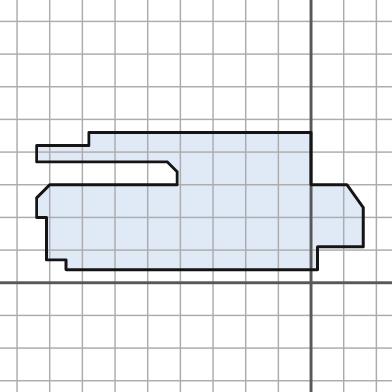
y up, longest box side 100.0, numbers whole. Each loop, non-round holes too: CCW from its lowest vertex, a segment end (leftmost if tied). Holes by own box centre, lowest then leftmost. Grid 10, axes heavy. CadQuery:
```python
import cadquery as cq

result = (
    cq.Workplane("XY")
    .moveTo(-75.0, 4.0)
    .lineTo(2.0, 4.0)
    .lineTo(2.0, 11.0)
    .lineTo(16.0, 11.0)
    .lineTo(16.0, 23.0)
    .lineTo(11.0, 30.0)
    .lineTo(0.0, 30.0)
    .lineTo(0.0, 46.0)
    .lineTo(-68.0, 46.0)
    .lineTo(-68.0, 42.0)
    .lineTo(-84.0, 42.0)
    .lineTo(-84.0, 37.0)
    .lineTo(-44.0, 37.0)
    .lineTo(-41.0, 34.0)
    .lineTo(-41.0, 30.0)
    .lineTo(-80.0, 30.0)
    .lineTo(-84.0, 26.0)
    .lineTo(-84.0, 20.0)
    .lineTo(-81.0, 20.0)
    .lineTo(-81.0, 7.0)
    .lineTo(-75.0, 7.0)
    .close()
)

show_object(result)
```